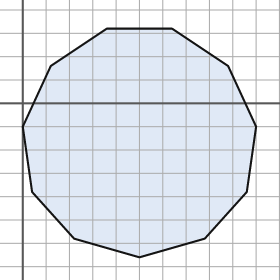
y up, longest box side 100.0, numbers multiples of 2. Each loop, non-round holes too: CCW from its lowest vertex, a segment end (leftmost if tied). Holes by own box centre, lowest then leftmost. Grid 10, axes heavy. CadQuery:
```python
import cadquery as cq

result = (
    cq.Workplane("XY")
    .moveTo(50.0, -66.0)
    .lineTo(78.0, -58.0)
    .lineTo(96.0, -38.0)
    .lineTo(100.0, -10.0)
    .lineTo(88.0, 16.0)
    .lineTo(64.0, 32.0)
    .lineTo(36.0, 32.0)
    .lineTo(12.0, 16.0)
    .lineTo(0.0, -10.0)
    .lineTo(4.0, -38.0)
    .lineTo(22.0, -58.0)
    .close()
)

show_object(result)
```